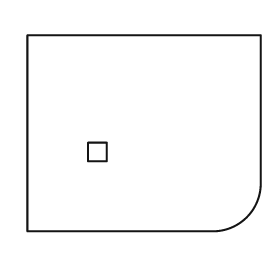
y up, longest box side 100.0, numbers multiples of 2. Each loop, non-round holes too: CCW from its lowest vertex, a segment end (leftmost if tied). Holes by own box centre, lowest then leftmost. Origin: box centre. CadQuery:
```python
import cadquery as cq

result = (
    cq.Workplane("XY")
    .moveTo(-50.0, -42.0)
    .lineTo(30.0, -42.0)
    .threePointArc((44.0, -36.0), (50.0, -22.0))
    .lineTo(50.0, 42.0)
    .lineTo(-50.0, 42.0)
    .close()
    .moveTo(-24.0, -12.0)
    .lineTo(-16.0, -12.0)
    .lineTo(-16.0, -4.0)
    .lineTo(-24.0, -4.0)
    .close()
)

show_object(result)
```